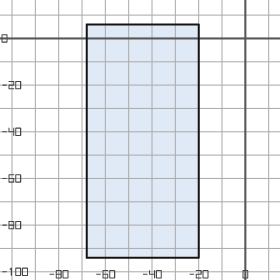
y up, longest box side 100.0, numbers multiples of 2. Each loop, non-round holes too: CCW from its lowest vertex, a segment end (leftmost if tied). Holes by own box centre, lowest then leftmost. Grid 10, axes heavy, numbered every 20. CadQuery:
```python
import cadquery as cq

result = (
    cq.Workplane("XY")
    .moveTo(-68.0, -94.0)
    .lineTo(-20.0, -94.0)
    .lineTo(-20.0, 6.0)
    .lineTo(-68.0, 6.0)
    .close()
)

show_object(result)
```